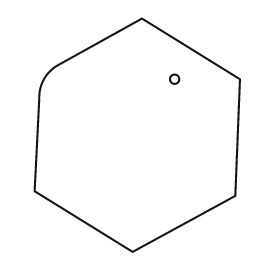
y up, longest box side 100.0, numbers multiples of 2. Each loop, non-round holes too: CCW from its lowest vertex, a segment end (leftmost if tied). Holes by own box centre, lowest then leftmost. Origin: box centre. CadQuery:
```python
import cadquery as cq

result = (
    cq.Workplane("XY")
    .moveTo(-2.0, -50.0)
    .lineTo(42.0, -26.0)
    .lineTo(44.0, 24.0)
    .lineTo(2.0, 50.0)
    .lineTo(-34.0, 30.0)
    .threePointArc((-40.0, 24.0), (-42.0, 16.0))
    .lineTo(-44.0, -24.0)
    .close()
    .moveTo(16.0, 24.0)
    .circle(2.0)
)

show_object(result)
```